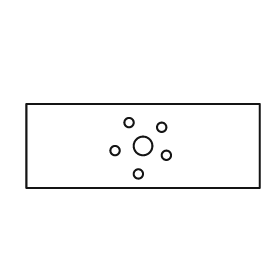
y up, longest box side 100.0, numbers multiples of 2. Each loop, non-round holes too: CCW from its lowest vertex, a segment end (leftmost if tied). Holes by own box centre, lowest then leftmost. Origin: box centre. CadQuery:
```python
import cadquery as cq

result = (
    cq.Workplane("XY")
    .moveTo(-50.0, -18.0)
    .lineTo(50.0, -18.0)
    .lineTo(50.0, 18.0)
    .lineTo(-50.0, 18.0)
    .close()
    .moveTo(-2.0, -12.0)
    .circle(2.0)
    .moveTo(10.0, -4.0)
    .circle(2.0)
    .moveTo(-12.0, -2.0)
    .circle(2.0)
    .moveTo(0.0, 0.0)
    .circle(4.0)
    .moveTo(8.0, 8.0)
    .circle(2.0)
    .moveTo(-6.0, 10.0)
    .circle(2.0)
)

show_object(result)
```